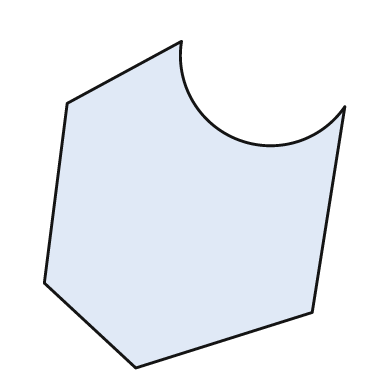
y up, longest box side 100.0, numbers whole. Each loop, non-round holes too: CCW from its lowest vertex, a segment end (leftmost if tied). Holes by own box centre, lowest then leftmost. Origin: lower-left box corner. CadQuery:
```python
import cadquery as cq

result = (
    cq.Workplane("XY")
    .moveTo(28.0, 0.0)
    .lineTo(82.0, 17.0)
    .lineTo(92.0, 80.0)
    .threePointArc((59.0, 70.0), (42.0, 100.0))
    .lineTo(7.0, 81.0)
    .lineTo(0.0, 26.0)
    .close()
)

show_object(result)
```